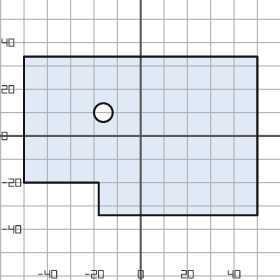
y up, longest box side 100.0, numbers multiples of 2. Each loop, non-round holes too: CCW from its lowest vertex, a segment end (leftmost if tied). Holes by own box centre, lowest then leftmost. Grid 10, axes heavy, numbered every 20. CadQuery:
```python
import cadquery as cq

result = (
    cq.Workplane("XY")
    .moveTo(-18.0, -34.0)
    .lineTo(50.0, -34.0)
    .lineTo(50.0, 34.0)
    .lineTo(-50.0, 34.0)
    .lineTo(-50.0, -20.0)
    .lineTo(-18.0, -20.0)
    .close()
    .moveTo(-16.0, 10.0)
    .circle(4.0)
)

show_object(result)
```